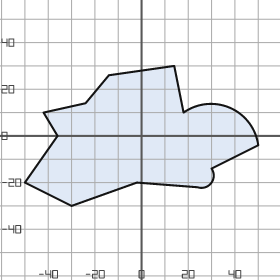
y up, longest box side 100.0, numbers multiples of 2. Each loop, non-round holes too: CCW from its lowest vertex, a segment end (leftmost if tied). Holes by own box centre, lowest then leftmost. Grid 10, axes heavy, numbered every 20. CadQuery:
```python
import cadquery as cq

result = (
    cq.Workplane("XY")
    .moveTo(-30.0, -30.0)
    .lineTo(-2.0, -20.0)
    .lineTo(24.0, -22.0)
    .threePointArc((30.0, -20.0), (30.0, -14.0))
    .lineTo(50.0, -4.0)
    .threePointArc((38.0, 12.0), (18.0, 10.0))
    .lineTo(14.0, 30.0)
    .lineTo(-14.0, 26.0)
    .lineTo(-24.0, 14.0)
    .lineTo(-42.0, 10.0)
    .lineTo(-36.0, 0.0)
    .lineTo(-50.0, -20.0)
    .close()
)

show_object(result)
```